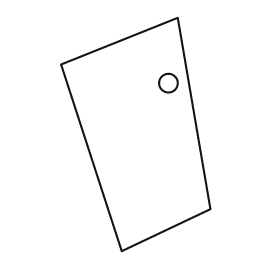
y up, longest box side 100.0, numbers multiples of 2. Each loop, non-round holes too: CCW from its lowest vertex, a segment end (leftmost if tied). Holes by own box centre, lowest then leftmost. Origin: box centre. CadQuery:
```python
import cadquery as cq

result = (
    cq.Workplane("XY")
    .moveTo(-6.0, -50.0)
    .lineTo(32.0, -32.0)
    .lineTo(18.0, 50.0)
    .lineTo(-32.0, 30.0)
    .close()
    .moveTo(14.0, 22.0)
    .circle(4.0)
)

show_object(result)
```